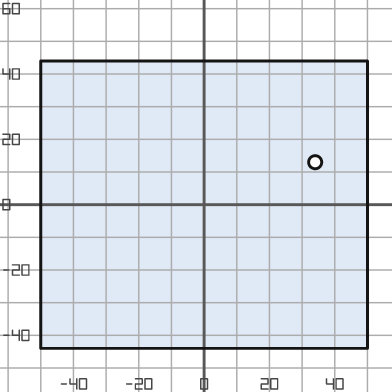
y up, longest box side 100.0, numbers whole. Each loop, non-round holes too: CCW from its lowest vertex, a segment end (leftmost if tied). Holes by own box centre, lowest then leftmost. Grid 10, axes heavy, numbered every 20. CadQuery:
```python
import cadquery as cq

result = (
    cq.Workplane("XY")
    .moveTo(-50.0, -44.0)
    .lineTo(50.0, -44.0)
    .lineTo(50.0, 44.0)
    .lineTo(-50.0, 44.0)
    .close()
    .moveTo(34.0, 13.0)
    .circle(2.0)
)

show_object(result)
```